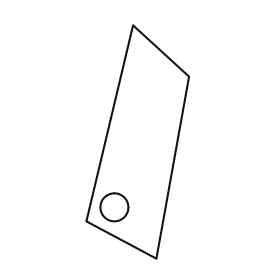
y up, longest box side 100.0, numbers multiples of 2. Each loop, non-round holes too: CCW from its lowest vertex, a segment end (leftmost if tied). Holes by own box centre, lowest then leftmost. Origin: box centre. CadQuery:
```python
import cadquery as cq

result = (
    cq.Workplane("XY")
    .moveTo(8.0, -50.0)
    .lineTo(22.0, 28.0)
    .lineTo(-2.0, 50.0)
    .lineTo(-22.0, -34.0)
    .close()
    .moveTo(-10.0, -28.0)
    .circle(6.0)
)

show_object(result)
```